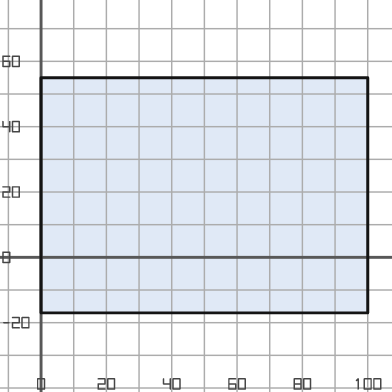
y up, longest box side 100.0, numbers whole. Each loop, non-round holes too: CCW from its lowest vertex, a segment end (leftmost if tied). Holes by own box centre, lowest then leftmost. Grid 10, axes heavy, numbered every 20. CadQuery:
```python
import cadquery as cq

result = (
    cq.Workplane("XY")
    .moveTo(0.0, -17.0)
    .lineTo(100.0, -17.0)
    .lineTo(100.0, 55.0)
    .lineTo(0.0, 55.0)
    .close()
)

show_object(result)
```